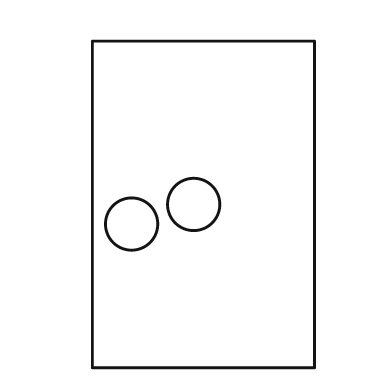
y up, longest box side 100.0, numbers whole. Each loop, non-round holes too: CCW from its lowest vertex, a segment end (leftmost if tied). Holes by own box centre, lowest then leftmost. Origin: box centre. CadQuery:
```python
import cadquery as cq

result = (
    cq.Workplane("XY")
    .moveTo(-34.0, -50.0)
    .lineTo(34.0, -50.0)
    .lineTo(34.0, 50.0)
    .lineTo(-34.0, 50.0)
    .close()
    .moveTo(-22.0, -6.0)
    .circle(8.0)
    .moveTo(-3.0, 0.0)
    .circle(8.0)
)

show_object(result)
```